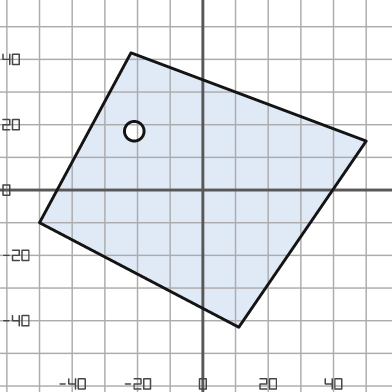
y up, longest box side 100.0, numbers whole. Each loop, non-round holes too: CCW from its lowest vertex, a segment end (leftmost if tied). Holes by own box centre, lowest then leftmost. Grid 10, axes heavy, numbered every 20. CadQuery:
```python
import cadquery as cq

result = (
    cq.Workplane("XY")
    .moveTo(11.0, -42.0)
    .lineTo(50.0, 15.0)
    .lineTo(-22.0, 42.0)
    .lineTo(-50.0, -10.0)
    .close()
    .moveTo(-21.0, 18.0)
    .circle(3.0)
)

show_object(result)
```